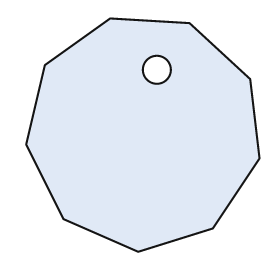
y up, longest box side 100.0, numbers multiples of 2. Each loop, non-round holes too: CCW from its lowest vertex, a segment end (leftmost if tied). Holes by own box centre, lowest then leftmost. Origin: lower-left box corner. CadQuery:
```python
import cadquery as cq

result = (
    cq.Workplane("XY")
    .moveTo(48.0, 0.0)
    .lineTo(80.0, 10.0)
    .lineTo(100.0, 40.0)
    .lineTo(96.0, 74.0)
    .lineTo(70.0, 98.0)
    .lineTo(36.0, 100.0)
    .lineTo(8.0, 80.0)
    .lineTo(0.0, 46.0)
    .lineTo(16.0, 14.0)
    .close()
    .moveTo(56.0, 78.0)
    .circle(6.0)
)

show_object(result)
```